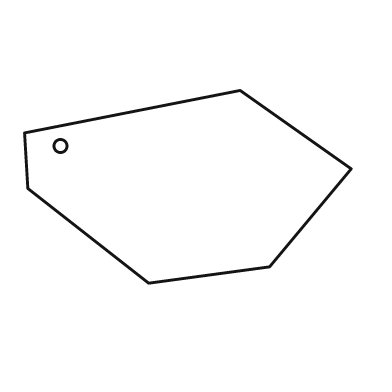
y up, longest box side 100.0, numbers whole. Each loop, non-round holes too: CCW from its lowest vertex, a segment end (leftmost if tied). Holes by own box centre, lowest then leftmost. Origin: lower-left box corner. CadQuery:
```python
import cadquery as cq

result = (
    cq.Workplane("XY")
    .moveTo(38.0, 0.0)
    .lineTo(75.0, 5.0)
    .lineTo(100.0, 35.0)
    .lineTo(66.0, 59.0)
    .lineTo(0.0, 46.0)
    .lineTo(1.0, 29.0)
    .close()
    .moveTo(11.0, 42.0)
    .circle(2.0)
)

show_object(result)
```